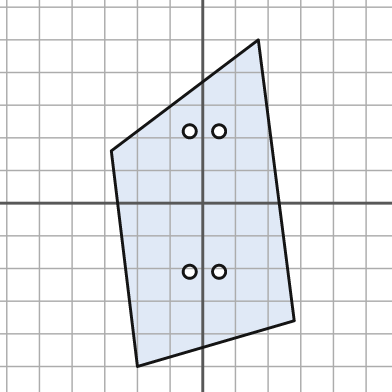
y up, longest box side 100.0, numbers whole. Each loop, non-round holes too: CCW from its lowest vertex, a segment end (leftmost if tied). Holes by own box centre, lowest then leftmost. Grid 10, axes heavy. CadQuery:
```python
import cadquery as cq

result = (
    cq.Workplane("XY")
    .moveTo(-20.0, -50.0)
    .lineTo(28.0, -36.0)
    .lineTo(17.0, 50.0)
    .lineTo(-28.0, 16.0)
    .close()
    .moveTo(-4.0, -21.0)
    .circle(2.0)
    .moveTo(5.0, -21.0)
    .circle(2.0)
    .moveTo(-4.0, 22.0)
    .circle(2.0)
    .moveTo(5.0, 22.0)
    .circle(2.0)
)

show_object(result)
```